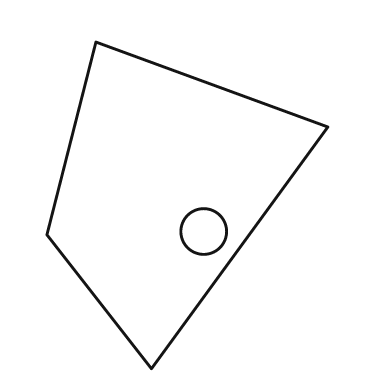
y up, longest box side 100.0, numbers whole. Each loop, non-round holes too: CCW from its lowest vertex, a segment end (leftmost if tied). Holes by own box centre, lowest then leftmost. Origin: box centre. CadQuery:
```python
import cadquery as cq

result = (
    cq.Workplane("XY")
    .moveTo(-11.0, -50.0)
    .lineTo(43.0, 24.0)
    .lineTo(-28.0, 50.0)
    .lineTo(-43.0, -9.0)
    .close()
    .moveTo(5.0, -8.0)
    .circle(7.0)
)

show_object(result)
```